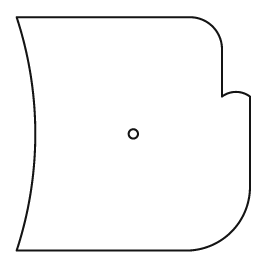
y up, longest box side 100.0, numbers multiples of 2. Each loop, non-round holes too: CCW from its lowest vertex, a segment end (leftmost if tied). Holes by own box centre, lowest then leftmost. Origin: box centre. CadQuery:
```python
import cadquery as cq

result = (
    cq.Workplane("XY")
    .moveTo(-50.0, -50.0)
    .lineTo(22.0, -50.0)
    .threePointArc((42.0, -42.0), (50.0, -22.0))
    .lineTo(50.0, 16.0)
    .threePointArc((44.0, 18.0), (38.0, 16.0))
    .lineTo(38.0, 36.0)
    .threePointArc((34.0, 46.0), (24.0, 50.0))
    .lineTo(-50.0, 50.0)
    .threePointArc((-42.0, 0.0), (-50.0, -50.0))
    .close()
    .moveTo(0.0, 0.0)
    .circle(2.0)
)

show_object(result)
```